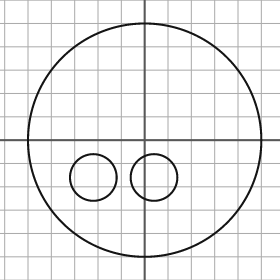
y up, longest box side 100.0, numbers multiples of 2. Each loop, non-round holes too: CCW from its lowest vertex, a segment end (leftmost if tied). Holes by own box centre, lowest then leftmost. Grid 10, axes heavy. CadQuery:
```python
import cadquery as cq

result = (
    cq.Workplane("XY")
    .moveTo(0.0, 0.0)
    .circle(50.0)
    .moveTo(-22.0, -16.0)
    .circle(10.0)
    .moveTo(4.0, -16.0)
    .circle(10.0)
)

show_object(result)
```